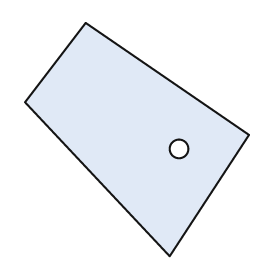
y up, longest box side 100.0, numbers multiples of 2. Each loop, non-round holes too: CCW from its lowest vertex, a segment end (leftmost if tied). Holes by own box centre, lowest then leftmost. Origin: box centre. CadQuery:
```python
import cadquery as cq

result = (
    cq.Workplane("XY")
    .moveTo(14.0, -50.0)
    .lineTo(48.0, 2.0)
    .lineTo(-22.0, 50.0)
    .lineTo(-48.0, 16.0)
    .close()
    .moveTo(18.0, -4.0)
    .circle(4.0)
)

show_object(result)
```